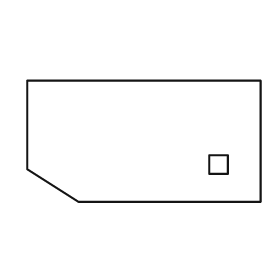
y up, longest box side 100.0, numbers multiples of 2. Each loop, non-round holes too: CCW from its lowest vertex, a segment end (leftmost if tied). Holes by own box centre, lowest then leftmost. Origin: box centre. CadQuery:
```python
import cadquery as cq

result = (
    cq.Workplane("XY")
    .moveTo(-28.0, -26.0)
    .lineTo(50.0, -26.0)
    .lineTo(50.0, 26.0)
    .lineTo(-50.0, 26.0)
    .lineTo(-50.0, -12.0)
    .close()
    .moveTo(28.0, -14.0)
    .lineTo(36.0, -14.0)
    .lineTo(36.0, -6.0)
    .lineTo(28.0, -6.0)
    .close()
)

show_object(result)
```